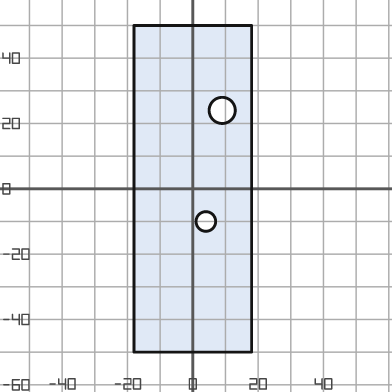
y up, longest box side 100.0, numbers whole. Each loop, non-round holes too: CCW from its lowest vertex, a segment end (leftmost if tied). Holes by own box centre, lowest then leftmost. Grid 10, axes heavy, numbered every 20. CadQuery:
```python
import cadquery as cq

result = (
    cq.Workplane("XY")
    .moveTo(-18.0, -50.0)
    .lineTo(18.0, -50.0)
    .lineTo(18.0, 50.0)
    .lineTo(-18.0, 50.0)
    .close()
    .moveTo(4.0, -10.0)
    .circle(3.0)
    .moveTo(9.0, 24.0)
    .circle(4.0)
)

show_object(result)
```